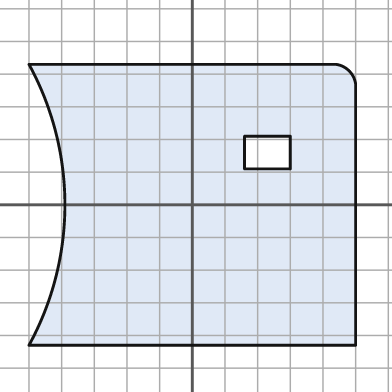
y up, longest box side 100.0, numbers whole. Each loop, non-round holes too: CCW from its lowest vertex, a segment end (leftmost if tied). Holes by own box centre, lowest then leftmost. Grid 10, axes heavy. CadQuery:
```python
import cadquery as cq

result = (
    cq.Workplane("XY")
    .moveTo(-50.0, -43.0)
    .lineTo(50.0, -43.0)
    .lineTo(50.0, 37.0)
    .threePointArc((48.0, 41.0), (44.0, 43.0))
    .lineTo(-50.0, 43.0)
    .threePointArc((-39.0, 0.0), (-50.0, -43.0))
    .close()
    .moveTo(16.0, 11.0)
    .lineTo(30.0, 11.0)
    .lineTo(30.0, 21.0)
    .lineTo(16.0, 21.0)
    .close()
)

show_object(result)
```